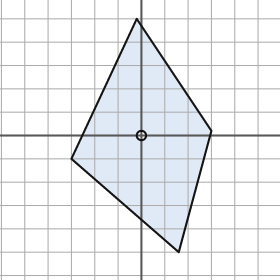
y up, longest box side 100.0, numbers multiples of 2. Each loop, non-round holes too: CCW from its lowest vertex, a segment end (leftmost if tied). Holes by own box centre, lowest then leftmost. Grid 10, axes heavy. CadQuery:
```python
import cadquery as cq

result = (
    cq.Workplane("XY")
    .moveTo(16.0, -50.0)
    .lineTo(30.0, 2.0)
    .lineTo(-2.0, 50.0)
    .lineTo(-30.0, -10.0)
    .close()
    .moveTo(0.0, 0.0)
    .circle(2.0)
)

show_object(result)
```